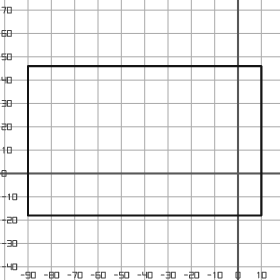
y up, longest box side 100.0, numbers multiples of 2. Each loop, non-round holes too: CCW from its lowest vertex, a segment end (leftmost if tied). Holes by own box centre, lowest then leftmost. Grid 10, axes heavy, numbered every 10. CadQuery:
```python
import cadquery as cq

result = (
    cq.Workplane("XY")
    .moveTo(-90.0, -18.0)
    .lineTo(10.0, -18.0)
    .lineTo(10.0, 46.0)
    .lineTo(-90.0, 46.0)
    .close()
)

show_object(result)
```